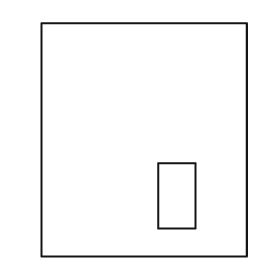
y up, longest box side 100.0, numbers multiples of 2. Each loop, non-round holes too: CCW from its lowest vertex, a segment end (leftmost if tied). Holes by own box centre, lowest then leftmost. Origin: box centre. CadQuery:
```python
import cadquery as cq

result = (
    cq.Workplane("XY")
    .moveTo(-44.0, -50.0)
    .lineTo(44.0, -50.0)
    .lineTo(44.0, 50.0)
    .lineTo(-44.0, 50.0)
    .close()
    .moveTo(6.0, -38.0)
    .lineTo(22.0, -38.0)
    .lineTo(22.0, -10.0)
    .lineTo(6.0, -10.0)
    .close()
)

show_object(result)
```